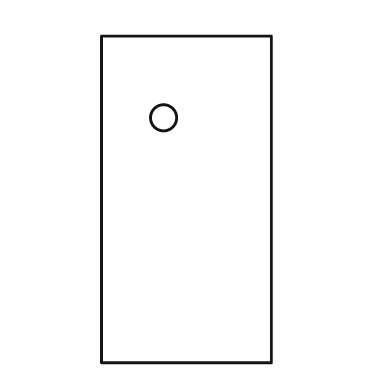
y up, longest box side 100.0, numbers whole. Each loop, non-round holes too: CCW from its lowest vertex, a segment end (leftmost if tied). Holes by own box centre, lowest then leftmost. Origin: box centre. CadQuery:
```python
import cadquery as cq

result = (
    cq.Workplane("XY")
    .moveTo(-26.0, -50.0)
    .lineTo(26.0, -50.0)
    .lineTo(26.0, 50.0)
    .lineTo(-26.0, 50.0)
    .close()
    .moveTo(-7.0, 25.0)
    .circle(4.0)
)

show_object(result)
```